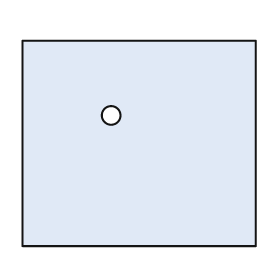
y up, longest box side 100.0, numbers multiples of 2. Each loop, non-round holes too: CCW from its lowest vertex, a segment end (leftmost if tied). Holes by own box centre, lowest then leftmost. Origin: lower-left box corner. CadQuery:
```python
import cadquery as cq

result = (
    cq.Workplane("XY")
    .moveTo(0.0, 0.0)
    .lineTo(100.0, 0.0)
    .lineTo(100.0, 88.0)
    .lineTo(0.0, 88.0)
    .close()
    .moveTo(38.0, 56.0)
    .circle(4.0)
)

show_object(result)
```